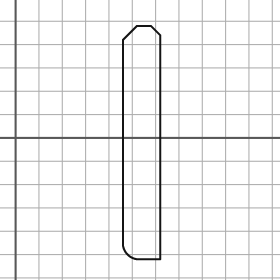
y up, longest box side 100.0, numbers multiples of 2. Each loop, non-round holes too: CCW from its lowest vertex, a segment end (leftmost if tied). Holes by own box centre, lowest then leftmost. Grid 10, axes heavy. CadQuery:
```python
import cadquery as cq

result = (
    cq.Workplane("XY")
    .moveTo(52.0, -52.0)
    .lineTo(62.0, -52.0)
    .lineTo(62.0, 44.0)
    .lineTo(58.0, 48.0)
    .lineTo(52.0, 48.0)
    .lineTo(46.0, 42.0)
    .lineTo(46.0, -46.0)
    .threePointArc((48.0, -50.0), (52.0, -52.0))
    .close()
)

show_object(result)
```